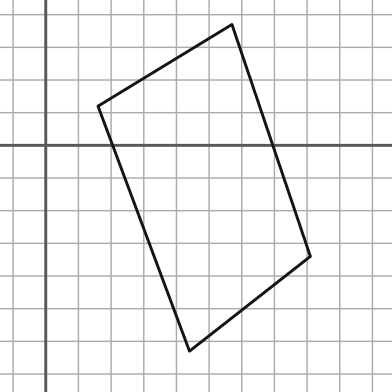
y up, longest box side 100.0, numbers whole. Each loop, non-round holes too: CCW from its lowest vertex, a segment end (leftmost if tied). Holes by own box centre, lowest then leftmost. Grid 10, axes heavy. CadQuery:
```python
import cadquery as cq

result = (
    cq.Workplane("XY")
    .moveTo(44.0, -63.0)
    .lineTo(81.0, -34.0)
    .lineTo(57.0, 37.0)
    .lineTo(16.0, 12.0)
    .close()
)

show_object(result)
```